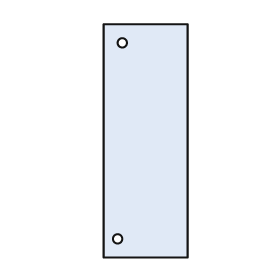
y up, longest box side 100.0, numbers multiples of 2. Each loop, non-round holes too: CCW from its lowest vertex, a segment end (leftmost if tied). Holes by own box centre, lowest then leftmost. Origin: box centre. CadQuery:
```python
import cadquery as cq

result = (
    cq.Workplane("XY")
    .moveTo(-18.0, -50.0)
    .lineTo(18.0, -50.0)
    .lineTo(18.0, 50.0)
    .lineTo(-18.0, 50.0)
    .close()
    .moveTo(-12.0, -42.0)
    .circle(2.0)
    .moveTo(-10.0, 42.0)
    .circle(2.0)
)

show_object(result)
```